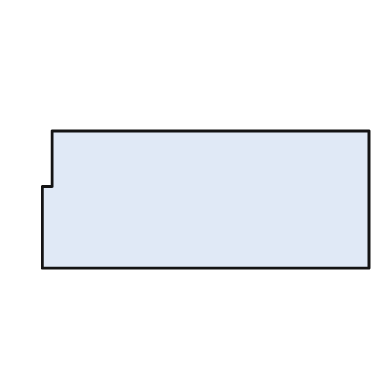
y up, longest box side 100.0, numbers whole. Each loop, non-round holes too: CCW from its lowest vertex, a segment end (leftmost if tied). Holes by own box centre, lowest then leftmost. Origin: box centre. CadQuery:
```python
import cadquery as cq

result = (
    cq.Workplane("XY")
    .moveTo(-50.0, -21.0)
    .lineTo(50.0, -21.0)
    .lineTo(50.0, 21.0)
    .lineTo(-47.0, 21.0)
    .lineTo(-47.0, 4.0)
    .lineTo(-50.0, 4.0)
    .close()
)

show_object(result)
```